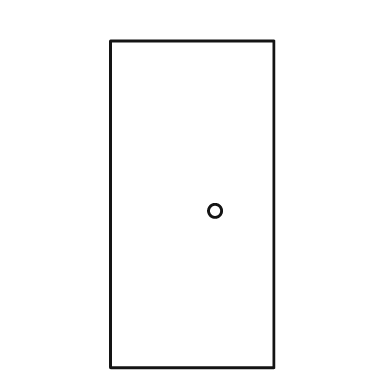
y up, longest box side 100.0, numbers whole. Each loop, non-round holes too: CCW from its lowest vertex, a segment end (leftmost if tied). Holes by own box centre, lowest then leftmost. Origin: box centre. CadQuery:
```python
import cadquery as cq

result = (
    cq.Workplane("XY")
    .moveTo(-25.0, -50.0)
    .lineTo(25.0, -50.0)
    .lineTo(25.0, 50.0)
    .lineTo(-25.0, 50.0)
    .close()
    .moveTo(7.0, -2.0)
    .circle(2.0)
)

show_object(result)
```